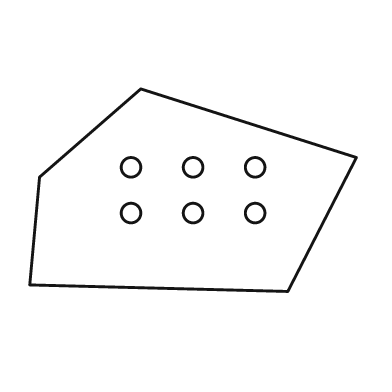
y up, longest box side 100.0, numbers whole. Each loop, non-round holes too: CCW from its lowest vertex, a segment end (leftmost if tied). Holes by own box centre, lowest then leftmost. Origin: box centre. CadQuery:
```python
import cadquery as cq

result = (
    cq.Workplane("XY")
    .moveTo(29.0, -31.0)
    .lineTo(50.0, 10.0)
    .lineTo(-16.0, 31.0)
    .lineTo(-47.0, 4.0)
    .lineTo(-50.0, -29.0)
    .close()
    .moveTo(-19.0, -7.0)
    .circle(3.0)
    .moveTo(0.0, -7.0)
    .circle(3.0)
    .moveTo(19.0, -7.0)
    .circle(3.0)
    .moveTo(-19.0, 7.0)
    .circle(3.0)
    .moveTo(0.0, 7.0)
    .circle(3.0)
    .moveTo(19.0, 7.0)
    .circle(3.0)
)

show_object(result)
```